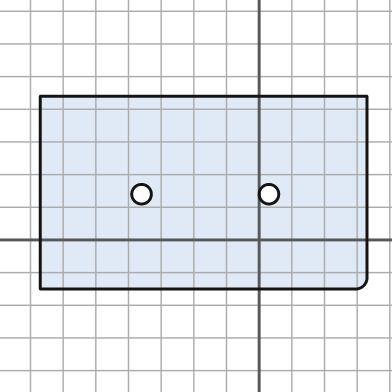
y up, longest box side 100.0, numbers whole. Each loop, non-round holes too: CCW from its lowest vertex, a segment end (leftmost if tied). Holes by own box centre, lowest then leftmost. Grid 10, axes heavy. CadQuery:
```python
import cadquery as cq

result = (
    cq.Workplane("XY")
    .moveTo(-67.0, -15.0)
    .lineTo(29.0, -15.0)
    .threePointArc((32.0, -14.0), (33.0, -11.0))
    .lineTo(33.0, 44.0)
    .lineTo(-67.0, 44.0)
    .close()
    .moveTo(-36.0, 14.0)
    .circle(3.0)
    .moveTo(3.0, 14.0)
    .circle(3.0)
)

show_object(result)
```